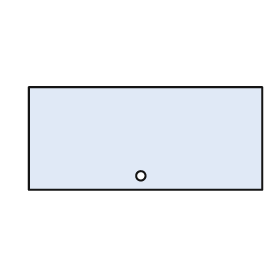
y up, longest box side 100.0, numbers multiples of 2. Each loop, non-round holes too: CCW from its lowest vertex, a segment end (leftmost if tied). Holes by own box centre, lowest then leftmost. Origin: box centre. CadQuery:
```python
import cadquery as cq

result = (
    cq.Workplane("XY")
    .moveTo(-50.0, -22.0)
    .lineTo(50.0, -22.0)
    .lineTo(50.0, 22.0)
    .lineTo(-50.0, 22.0)
    .close()
    .moveTo(-2.0, -16.0)
    .circle(2.0)
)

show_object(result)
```